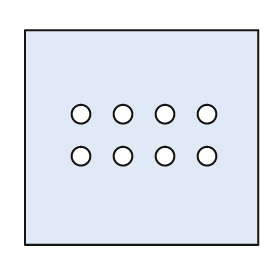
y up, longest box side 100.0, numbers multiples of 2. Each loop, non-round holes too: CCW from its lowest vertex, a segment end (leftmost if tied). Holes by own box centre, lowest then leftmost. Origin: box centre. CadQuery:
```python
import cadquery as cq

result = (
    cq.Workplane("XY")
    .moveTo(-50.0, -46.0)
    .lineTo(50.0, -46.0)
    .lineTo(50.0, 46.0)
    .lineTo(-50.0, 46.0)
    .close()
    .moveTo(-26.0, -8.0)
    .circle(4.0)
    .moveTo(-8.0, -8.0)
    .circle(4.0)
    .moveTo(10.0, -8.0)
    .circle(4.0)
    .moveTo(28.0, -8.0)
    .circle(4.0)
    .moveTo(-26.0, 10.0)
    .circle(4.0)
    .moveTo(-8.0, 10.0)
    .circle(4.0)
    .moveTo(10.0, 10.0)
    .circle(4.0)
    .moveTo(28.0, 10.0)
    .circle(4.0)
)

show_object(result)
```